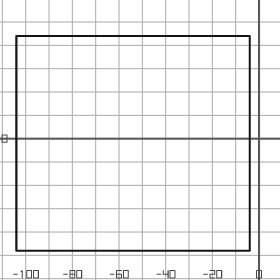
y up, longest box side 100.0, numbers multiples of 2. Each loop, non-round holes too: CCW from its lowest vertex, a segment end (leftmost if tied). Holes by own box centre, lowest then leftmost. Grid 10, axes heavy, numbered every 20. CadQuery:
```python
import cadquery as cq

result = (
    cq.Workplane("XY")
    .moveTo(-104.0, -48.0)
    .lineTo(-4.0, -48.0)
    .lineTo(-4.0, 44.0)
    .lineTo(-104.0, 44.0)
    .close()
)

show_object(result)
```